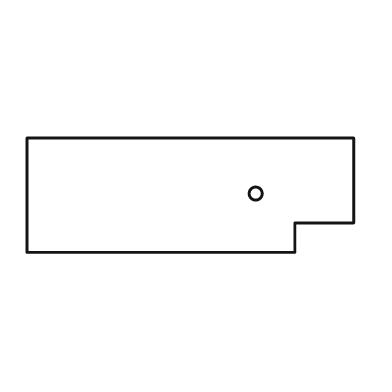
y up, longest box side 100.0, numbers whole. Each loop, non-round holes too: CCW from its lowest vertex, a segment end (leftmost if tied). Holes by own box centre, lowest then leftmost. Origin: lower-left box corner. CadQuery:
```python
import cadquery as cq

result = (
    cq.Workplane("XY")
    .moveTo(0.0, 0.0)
    .lineTo(82.0, 0.0)
    .lineTo(82.0, 9.0)
    .lineTo(100.0, 9.0)
    .lineTo(100.0, 35.0)
    .lineTo(0.0, 35.0)
    .close()
    .moveTo(70.0, 18.0)
    .circle(2.0)
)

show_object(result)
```